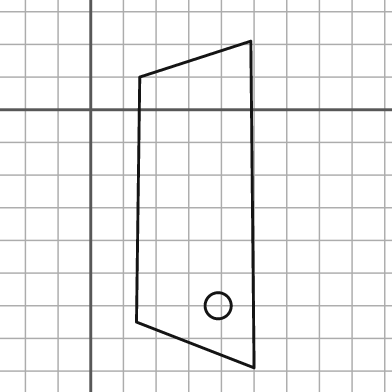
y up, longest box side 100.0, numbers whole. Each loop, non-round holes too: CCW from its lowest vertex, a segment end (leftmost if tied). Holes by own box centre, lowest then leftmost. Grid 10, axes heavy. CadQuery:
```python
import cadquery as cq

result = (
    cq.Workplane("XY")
    .moveTo(50.0, -79.0)
    .lineTo(49.0, 21.0)
    .lineTo(15.0, 10.0)
    .lineTo(14.0, -65.0)
    .close()
    .moveTo(39.0, -60.0)
    .circle(4.0)
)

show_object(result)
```